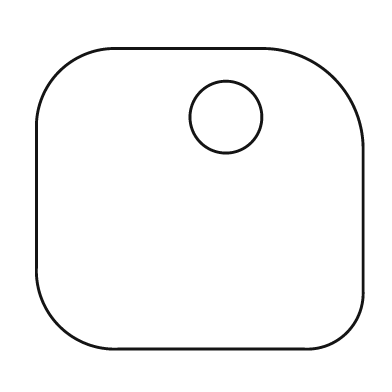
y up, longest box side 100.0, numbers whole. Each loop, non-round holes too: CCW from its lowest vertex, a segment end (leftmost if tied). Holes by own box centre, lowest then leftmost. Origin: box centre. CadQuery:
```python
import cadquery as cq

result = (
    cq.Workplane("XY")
    .moveTo(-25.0, -46.0)
    .lineTo(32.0, -46.0)
    .threePointArc((45.0, -41.0), (50.0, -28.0))
    .lineTo(50.0, 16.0)
    .threePointArc((41.0, 37.0), (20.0, 46.0))
    .lineTo(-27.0, 46.0)
    .threePointArc((-43.0, 39.0), (-50.0, 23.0))
    .lineTo(-50.0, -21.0)
    .threePointArc((-43.0, -39.0), (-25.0, -46.0))
    .close()
    .moveTo(8.0, 25.0)
    .circle(11.0)
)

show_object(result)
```